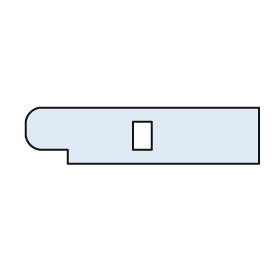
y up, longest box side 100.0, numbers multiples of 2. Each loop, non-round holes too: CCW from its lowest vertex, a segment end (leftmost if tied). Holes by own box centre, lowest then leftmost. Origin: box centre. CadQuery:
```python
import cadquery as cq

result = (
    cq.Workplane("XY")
    .moveTo(-32.0, -12.0)
    .lineTo(50.0, -12.0)
    .lineTo(50.0, 12.0)
    .lineTo(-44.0, 12.0)
    .threePointArc((-48.0, 10.0), (-50.0, 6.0))
    .lineTo(-50.0, 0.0)
    .threePointArc((-48.0, -4.0), (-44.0, -6.0))
    .lineTo(-32.0, -6.0)
    .close()
    .moveTo(-4.0, -6.0)
    .lineTo(4.0, -6.0)
    .lineTo(4.0, 6.0)
    .lineTo(-4.0, 6.0)
    .close()
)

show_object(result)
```